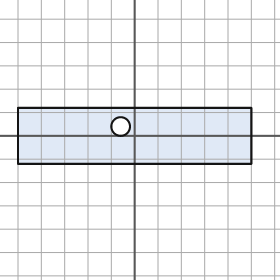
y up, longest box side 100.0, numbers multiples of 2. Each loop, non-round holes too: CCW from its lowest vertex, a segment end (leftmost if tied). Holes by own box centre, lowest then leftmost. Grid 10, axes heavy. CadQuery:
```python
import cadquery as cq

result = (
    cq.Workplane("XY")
    .moveTo(-50.0, -12.0)
    .lineTo(50.0, -12.0)
    .lineTo(50.0, 12.0)
    .lineTo(-50.0, 12.0)
    .close()
    .moveTo(-6.0, 4.0)
    .circle(4.0)
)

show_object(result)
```